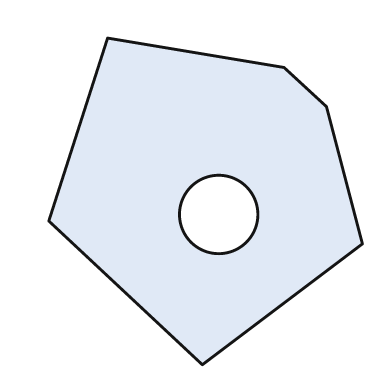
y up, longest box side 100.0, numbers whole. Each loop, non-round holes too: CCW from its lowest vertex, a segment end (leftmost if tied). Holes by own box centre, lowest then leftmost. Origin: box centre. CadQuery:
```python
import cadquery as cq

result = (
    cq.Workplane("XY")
    .moveTo(-1.0, -50.0)
    .lineTo(48.0, -13.0)
    .lineTo(37.0, 29.0)
    .lineTo(24.0, 41.0)
    .lineTo(-30.0, 50.0)
    .lineTo(-48.0, -6.0)
    .close()
    .moveTo(4.0, -4.0)
    .circle(12.0)
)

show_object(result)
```